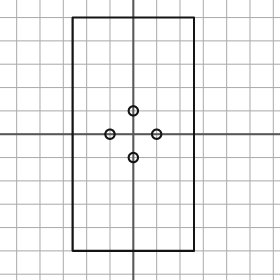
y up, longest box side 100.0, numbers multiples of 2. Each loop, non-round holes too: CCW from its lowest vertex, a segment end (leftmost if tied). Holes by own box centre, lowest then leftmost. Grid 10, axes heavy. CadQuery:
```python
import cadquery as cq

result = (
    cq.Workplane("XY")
    .moveTo(-26.0, -50.0)
    .lineTo(26.0, -50.0)
    .lineTo(26.0, 50.0)
    .lineTo(-26.0, 50.0)
    .close()
    .moveTo(0.0, -10.0)
    .circle(2.0)
    .moveTo(-10.0, 0.0)
    .circle(2.0)
    .moveTo(10.0, 0.0)
    .circle(2.0)
    .moveTo(0.0, 10.0)
    .circle(2.0)
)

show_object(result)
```